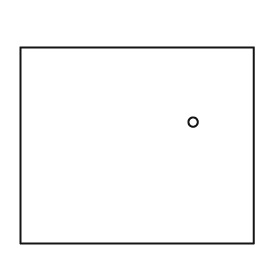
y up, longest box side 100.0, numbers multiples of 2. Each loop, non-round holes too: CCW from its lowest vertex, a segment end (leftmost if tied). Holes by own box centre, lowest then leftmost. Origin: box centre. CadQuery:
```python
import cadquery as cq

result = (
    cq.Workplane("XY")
    .moveTo(-50.0, -42.0)
    .lineTo(50.0, -42.0)
    .lineTo(50.0, 42.0)
    .lineTo(-50.0, 42.0)
    .close()
    .moveTo(24.0, 10.0)
    .circle(2.0)
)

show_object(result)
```